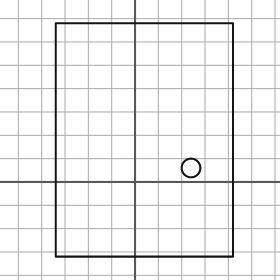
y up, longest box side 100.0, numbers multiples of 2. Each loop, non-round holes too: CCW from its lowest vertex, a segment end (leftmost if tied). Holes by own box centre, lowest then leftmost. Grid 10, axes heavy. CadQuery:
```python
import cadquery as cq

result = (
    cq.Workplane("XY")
    .moveTo(-34.0, -32.0)
    .lineTo(42.0, -32.0)
    .lineTo(42.0, 68.0)
    .lineTo(-34.0, 68.0)
    .close()
    .moveTo(24.0, 6.0)
    .circle(4.0)
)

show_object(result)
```